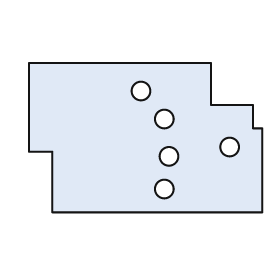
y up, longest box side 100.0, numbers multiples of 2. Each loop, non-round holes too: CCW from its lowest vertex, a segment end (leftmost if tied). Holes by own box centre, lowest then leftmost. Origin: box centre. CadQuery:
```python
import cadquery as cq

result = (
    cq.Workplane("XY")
    .moveTo(-40.0, -32.0)
    .lineTo(50.0, -32.0)
    .lineTo(50.0, 4.0)
    .lineTo(46.0, 4.0)
    .lineTo(46.0, 14.0)
    .lineTo(28.0, 14.0)
    .lineTo(28.0, 32.0)
    .lineTo(-50.0, 32.0)
    .lineTo(-50.0, -6.0)
    .lineTo(-40.0, -6.0)
    .close()
    .moveTo(8.0, -22.0)
    .circle(4.0)
    .moveTo(10.0, -8.0)
    .circle(4.0)
    .moveTo(36.0, -4.0)
    .circle(4.0)
    .moveTo(8.0, 8.0)
    .circle(4.0)
    .moveTo(-2.0, 20.0)
    .circle(4.0)
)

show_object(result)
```